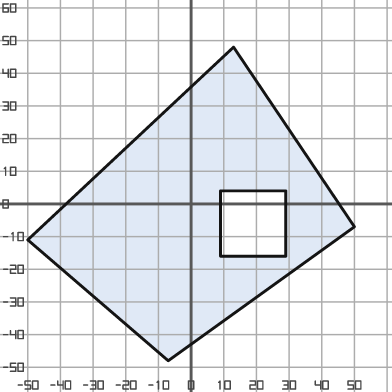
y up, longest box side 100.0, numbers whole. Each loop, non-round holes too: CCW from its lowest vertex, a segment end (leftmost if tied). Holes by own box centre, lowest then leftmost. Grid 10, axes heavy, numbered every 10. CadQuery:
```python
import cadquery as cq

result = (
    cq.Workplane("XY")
    .moveTo(-7.0, -48.0)
    .lineTo(50.0, -7.0)
    .lineTo(13.0, 48.0)
    .lineTo(-50.0, -11.0)
    .close()
    .moveTo(9.0, -16.0)
    .lineTo(29.0, -16.0)
    .lineTo(29.0, 4.0)
    .lineTo(9.0, 4.0)
    .close()
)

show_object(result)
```